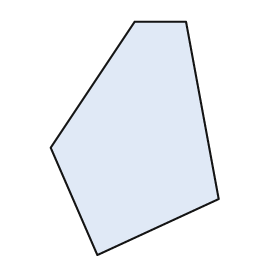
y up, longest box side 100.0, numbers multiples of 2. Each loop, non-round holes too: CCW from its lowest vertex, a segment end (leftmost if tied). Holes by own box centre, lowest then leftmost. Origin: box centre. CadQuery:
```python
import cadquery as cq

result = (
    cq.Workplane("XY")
    .moveTo(-16.0, -50.0)
    .lineTo(36.0, -26.0)
    .lineTo(22.0, 50.0)
    .lineTo(0.0, 50.0)
    .lineTo(-36.0, -4.0)
    .close()
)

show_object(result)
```